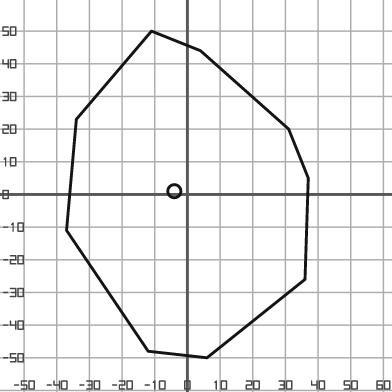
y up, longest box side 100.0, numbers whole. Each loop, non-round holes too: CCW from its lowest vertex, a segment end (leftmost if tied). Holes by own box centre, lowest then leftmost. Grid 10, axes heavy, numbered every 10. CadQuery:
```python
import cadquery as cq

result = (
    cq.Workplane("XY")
    .moveTo(6.0, -50.0)
    .lineTo(36.0, -26.0)
    .lineTo(37.0, 5.0)
    .lineTo(31.0, 20.0)
    .lineTo(4.0, 44.0)
    .lineTo(-11.0, 50.0)
    .lineTo(-34.0, 23.0)
    .lineTo(-37.0, -11.0)
    .lineTo(-12.0, -48.0)
    .close()
    .moveTo(-4.0, 1.0)
    .circle(2.0)
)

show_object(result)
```